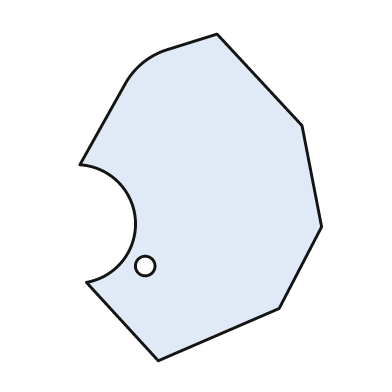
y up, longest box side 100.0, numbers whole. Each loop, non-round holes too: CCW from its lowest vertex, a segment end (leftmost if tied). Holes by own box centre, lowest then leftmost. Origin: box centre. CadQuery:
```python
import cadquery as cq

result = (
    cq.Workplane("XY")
    .moveTo(-13.0, -50.0)
    .lineTo(24.0, -34.0)
    .lineTo(37.0, -9.0)
    .lineTo(31.0, 22.0)
    .lineTo(5.0, 50.0)
    .lineTo(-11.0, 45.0)
    .threePointArc((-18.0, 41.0), (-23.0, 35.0))
    .lineTo(-37.0, 10.0)
    .threePointArc((-20.0, -7.0), (-35.0, -26.0))
    .close()
    .moveTo(-17.0, -21.0)
    .circle(3.0)
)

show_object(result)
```